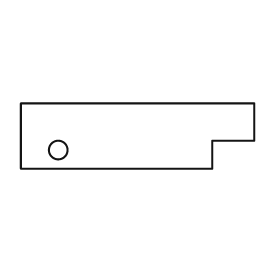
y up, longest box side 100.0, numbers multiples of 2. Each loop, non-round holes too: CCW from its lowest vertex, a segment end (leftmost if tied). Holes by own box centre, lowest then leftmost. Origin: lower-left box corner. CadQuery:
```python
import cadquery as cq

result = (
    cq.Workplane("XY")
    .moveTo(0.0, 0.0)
    .lineTo(82.0, 0.0)
    .lineTo(82.0, 12.0)
    .lineTo(100.0, 12.0)
    .lineTo(100.0, 28.0)
    .lineTo(0.0, 28.0)
    .close()
    .moveTo(16.0, 8.0)
    .circle(4.0)
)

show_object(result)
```